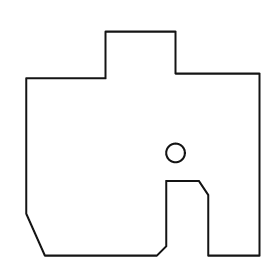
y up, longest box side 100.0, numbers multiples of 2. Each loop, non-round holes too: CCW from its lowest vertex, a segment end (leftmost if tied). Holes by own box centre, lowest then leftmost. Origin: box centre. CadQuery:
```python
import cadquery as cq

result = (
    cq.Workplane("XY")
    .moveTo(-42.0, -48.0)
    .lineTo(6.0, -48.0)
    .lineTo(10.0, -44.0)
    .lineTo(10.0, -16.0)
    .lineTo(24.0, -16.0)
    .lineTo(28.0, -22.0)
    .lineTo(28.0, -48.0)
    .lineTo(50.0, -48.0)
    .lineTo(50.0, 30.0)
    .lineTo(14.0, 30.0)
    .lineTo(14.0, 48.0)
    .lineTo(-16.0, 48.0)
    .lineTo(-16.0, 28.0)
    .lineTo(-50.0, 28.0)
    .lineTo(-50.0, -30.0)
    .close()
    .moveTo(14.0, -4.0)
    .circle(4.0)
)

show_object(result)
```